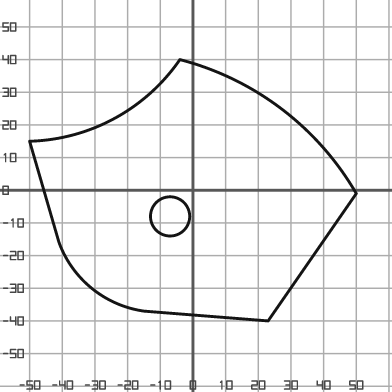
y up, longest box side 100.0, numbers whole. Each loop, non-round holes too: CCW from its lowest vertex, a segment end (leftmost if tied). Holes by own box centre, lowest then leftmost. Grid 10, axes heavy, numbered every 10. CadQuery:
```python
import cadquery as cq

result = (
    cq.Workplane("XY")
    .moveTo(23.0, -40.0)
    .lineTo(50.0, -1.0)
    .threePointArc((27.0, 25.0), (-4.0, 40.0))
    .threePointArc((-24.0, 22.0), (-50.0, 15.0))
    .lineTo(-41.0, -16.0)
    .threePointArc((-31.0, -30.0), (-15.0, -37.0))
    .close()
    .moveTo(-7.0, -8.0)
    .circle(6.0)
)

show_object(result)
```